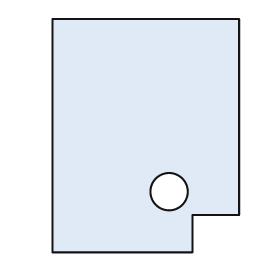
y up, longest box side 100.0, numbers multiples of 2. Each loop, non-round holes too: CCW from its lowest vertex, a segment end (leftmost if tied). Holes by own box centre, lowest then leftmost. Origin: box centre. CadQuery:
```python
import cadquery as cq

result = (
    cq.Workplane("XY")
    .moveTo(-40.0, -50.0)
    .lineTo(20.0, -50.0)
    .lineTo(20.0, -34.0)
    .lineTo(40.0, -34.0)
    .lineTo(40.0, 50.0)
    .lineTo(-40.0, 50.0)
    .close()
    .moveTo(10.0, -24.0)
    .circle(8.0)
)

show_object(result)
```